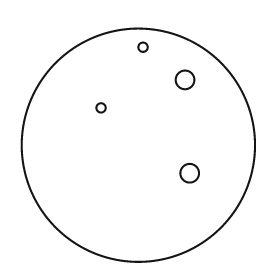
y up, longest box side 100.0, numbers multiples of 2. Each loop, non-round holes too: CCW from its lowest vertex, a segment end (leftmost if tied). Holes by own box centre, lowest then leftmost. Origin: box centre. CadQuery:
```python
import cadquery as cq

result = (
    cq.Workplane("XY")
    .moveTo(0.0, 0.0)
    .circle(50.0)
    .moveTo(22.0, -12.0)
    .circle(4.0)
    .moveTo(-16.0, 16.0)
    .circle(2.0)
    .moveTo(20.0, 28.0)
    .circle(4.0)
    .moveTo(2.0, 42.0)
    .circle(2.0)
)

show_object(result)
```